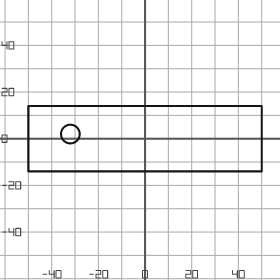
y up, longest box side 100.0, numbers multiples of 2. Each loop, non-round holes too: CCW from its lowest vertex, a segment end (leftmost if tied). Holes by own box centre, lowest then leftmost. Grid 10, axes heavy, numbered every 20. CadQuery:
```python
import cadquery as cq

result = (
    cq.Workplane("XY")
    .moveTo(-50.0, -14.0)
    .lineTo(50.0, -14.0)
    .lineTo(50.0, 14.0)
    .lineTo(-50.0, 14.0)
    .close()
    .moveTo(-32.0, 2.0)
    .circle(4.0)
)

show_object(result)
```